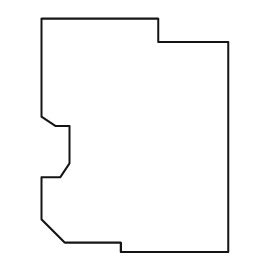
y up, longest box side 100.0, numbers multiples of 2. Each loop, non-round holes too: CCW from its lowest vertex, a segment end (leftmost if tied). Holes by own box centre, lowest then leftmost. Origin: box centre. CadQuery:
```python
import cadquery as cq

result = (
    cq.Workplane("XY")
    .moveTo(-6.0, -50.0)
    .lineTo(40.0, -50.0)
    .lineTo(40.0, 40.0)
    .lineTo(10.0, 40.0)
    .lineTo(10.0, 50.0)
    .lineTo(-40.0, 50.0)
    .lineTo(-40.0, 8.0)
    .lineTo(-34.0, 4.0)
    .lineTo(-28.0, 4.0)
    .lineTo(-28.0, -12.0)
    .lineTo(-32.0, -18.0)
    .lineTo(-40.0, -18.0)
    .lineTo(-40.0, -36.0)
    .lineTo(-30.0, -46.0)
    .lineTo(-6.0, -46.0)
    .close()
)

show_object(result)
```